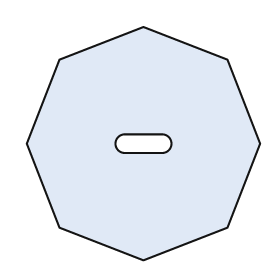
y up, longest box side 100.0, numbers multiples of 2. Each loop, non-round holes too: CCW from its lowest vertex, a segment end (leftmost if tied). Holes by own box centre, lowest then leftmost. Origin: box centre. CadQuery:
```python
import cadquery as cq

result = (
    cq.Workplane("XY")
    .moveTo(0.0, -50.0)
    .lineTo(36.0, -36.0)
    .lineTo(50.0, 0.0)
    .lineTo(36.0, 36.0)
    .lineTo(0.0, 50.0)
    .lineTo(-36.0, 36.0)
    .lineTo(-50.0, 0.0)
    .lineTo(-36.0, -36.0)
    .close()
    .moveTo(-8.0, -4.0)
    .lineTo(8.0, -4.0)
    .threePointArc((12.0, 0.0), (8.0, 4.0))
    .lineTo(-8.0, 4.0)
    .threePointArc((-12.0, 0.0), (-8.0, -4.0))
    .close()
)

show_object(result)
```